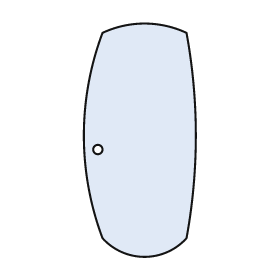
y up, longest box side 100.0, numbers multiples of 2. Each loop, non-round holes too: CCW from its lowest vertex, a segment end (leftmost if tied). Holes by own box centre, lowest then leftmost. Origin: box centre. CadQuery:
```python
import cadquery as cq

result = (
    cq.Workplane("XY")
    .moveTo(-16.0, -42.0)
    .threePointArc((2.0, -50.0), (20.0, -42.0))
    .threePointArc((24.0, 2.0), (20.0, 46.0))
    .threePointArc((2.0, 50.0), (-16.0, 46.0))
    .threePointArc((-24.0, 2.0), (-16.0, -42.0))
    .close()
    .moveTo(-18.0, -4.0)
    .circle(2.0)
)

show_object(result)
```